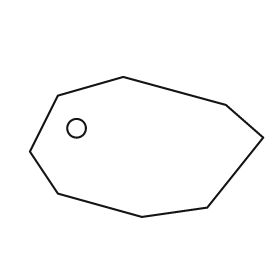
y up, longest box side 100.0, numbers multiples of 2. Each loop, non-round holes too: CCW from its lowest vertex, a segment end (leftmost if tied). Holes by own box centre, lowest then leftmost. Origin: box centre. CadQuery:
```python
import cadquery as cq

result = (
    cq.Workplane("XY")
    .moveTo(-2.0, -30.0)
    .lineTo(26.0, -26.0)
    .lineTo(50.0, 4.0)
    .lineTo(34.0, 18.0)
    .lineTo(-10.0, 30.0)
    .lineTo(-38.0, 22.0)
    .lineTo(-50.0, -2.0)
    .lineTo(-38.0, -20.0)
    .close()
    .moveTo(-30.0, 8.0)
    .circle(4.0)
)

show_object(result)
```